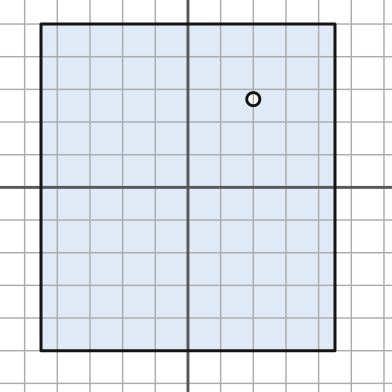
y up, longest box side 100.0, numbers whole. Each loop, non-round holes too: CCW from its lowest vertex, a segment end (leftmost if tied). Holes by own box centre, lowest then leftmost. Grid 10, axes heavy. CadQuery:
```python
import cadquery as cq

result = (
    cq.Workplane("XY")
    .moveTo(-45.0, -50.0)
    .lineTo(45.0, -50.0)
    .lineTo(45.0, 50.0)
    .lineTo(-45.0, 50.0)
    .close()
    .moveTo(20.0, 27.0)
    .circle(2.0)
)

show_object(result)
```